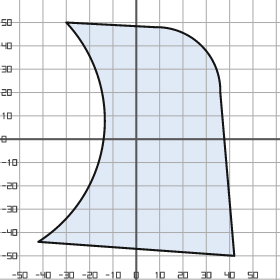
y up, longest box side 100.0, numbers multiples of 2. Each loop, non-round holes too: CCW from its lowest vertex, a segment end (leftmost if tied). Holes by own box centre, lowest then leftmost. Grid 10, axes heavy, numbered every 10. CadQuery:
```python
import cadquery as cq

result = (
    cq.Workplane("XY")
    .moveTo(42.0, -50.0)
    .lineTo(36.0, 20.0)
    .threePointArc((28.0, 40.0), (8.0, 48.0))
    .lineTo(-30.0, 50.0)
    .threePointArc((-14.0, 0.0), (-42.0, -44.0))
    .close()
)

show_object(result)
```